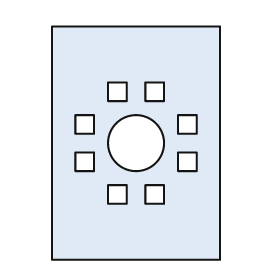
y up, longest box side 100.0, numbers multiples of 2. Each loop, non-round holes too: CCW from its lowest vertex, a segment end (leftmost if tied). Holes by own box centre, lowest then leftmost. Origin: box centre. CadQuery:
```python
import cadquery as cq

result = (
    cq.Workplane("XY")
    .moveTo(-36.0, -50.0)
    .lineTo(36.0, -50.0)
    .lineTo(36.0, 50.0)
    .lineTo(-36.0, 50.0)
    .close()
    .moveTo(-12.0, -26.0)
    .lineTo(-4.0, -26.0)
    .lineTo(-4.0, -18.0)
    .lineTo(-12.0, -18.0)
    .close()
    .moveTo(4.0, -26.0)
    .lineTo(12.0, -26.0)
    .lineTo(12.0, -18.0)
    .lineTo(4.0, -18.0)
    .close()
    .moveTo(-26.0, -12.0)
    .lineTo(-18.0, -12.0)
    .lineTo(-18.0, -4.0)
    .lineTo(-26.0, -4.0)
    .close()
    .moveTo(18.0, -12.0)
    .lineTo(26.0, -12.0)
    .lineTo(26.0, -4.0)
    .lineTo(18.0, -4.0)
    .close()
    .moveTo(0.0, 0.0)
    .circle(12.0)
    .moveTo(-26.0, 4.0)
    .lineTo(-18.0, 4.0)
    .lineTo(-18.0, 12.0)
    .lineTo(-26.0, 12.0)
    .close()
    .moveTo(18.0, 4.0)
    .lineTo(26.0, 4.0)
    .lineTo(26.0, 12.0)
    .lineTo(18.0, 12.0)
    .close()
    .moveTo(-12.0, 18.0)
    .lineTo(-4.0, 18.0)
    .lineTo(-4.0, 26.0)
    .lineTo(-12.0, 26.0)
    .close()
    .moveTo(4.0, 18.0)
    .lineTo(12.0, 18.0)
    .lineTo(12.0, 26.0)
    .lineTo(4.0, 26.0)
    .close()
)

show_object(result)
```